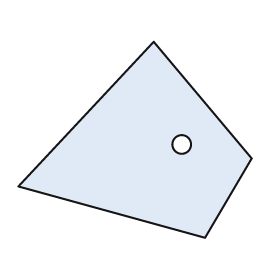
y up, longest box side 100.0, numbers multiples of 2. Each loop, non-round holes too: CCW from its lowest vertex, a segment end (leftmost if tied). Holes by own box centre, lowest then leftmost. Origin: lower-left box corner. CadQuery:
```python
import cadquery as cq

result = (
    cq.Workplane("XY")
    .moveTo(80.0, 0.0)
    .lineTo(100.0, 34.0)
    .lineTo(58.0, 84.0)
    .lineTo(0.0, 22.0)
    .close()
    .moveTo(70.0, 40.0)
    .circle(4.0)
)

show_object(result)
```